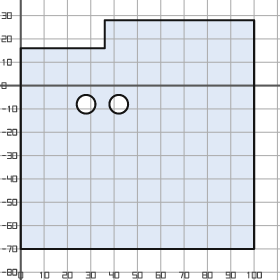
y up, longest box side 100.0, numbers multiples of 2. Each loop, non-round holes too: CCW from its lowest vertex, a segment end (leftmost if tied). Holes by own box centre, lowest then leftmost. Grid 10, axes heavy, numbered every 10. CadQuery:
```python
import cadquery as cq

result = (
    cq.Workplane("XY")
    .moveTo(0.0, -70.0)
    .lineTo(100.0, -70.0)
    .lineTo(100.0, 28.0)
    .lineTo(36.0, 28.0)
    .lineTo(36.0, 16.0)
    .lineTo(0.0, 16.0)
    .close()
    .moveTo(28.0, -8.0)
    .circle(4.0)
    .moveTo(42.0, -8.0)
    .circle(4.0)
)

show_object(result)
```